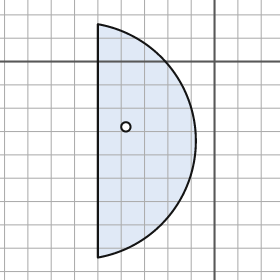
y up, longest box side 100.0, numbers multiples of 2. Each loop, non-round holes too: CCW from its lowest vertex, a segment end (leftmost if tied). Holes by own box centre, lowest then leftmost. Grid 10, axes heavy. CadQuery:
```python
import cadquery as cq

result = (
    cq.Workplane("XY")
    .moveTo(-50.0, -84.0)
    .threePointArc((-8.0, -34.0), (-50.0, 16.0))
    .close()
    .moveTo(-38.0, -28.0)
    .circle(2.0)
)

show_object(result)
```